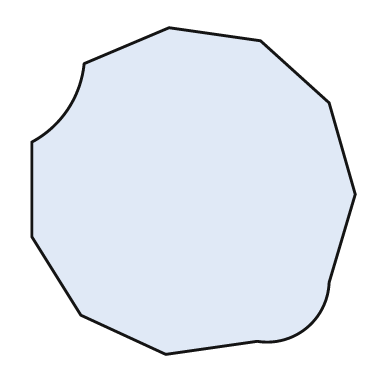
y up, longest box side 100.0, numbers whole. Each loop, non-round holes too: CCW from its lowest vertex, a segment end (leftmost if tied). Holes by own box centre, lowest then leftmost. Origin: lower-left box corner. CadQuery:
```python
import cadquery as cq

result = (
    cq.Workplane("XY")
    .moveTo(41.0, 0.0)
    .lineTo(69.0, 4.0)
    .threePointArc((84.0, 8.0), (91.0, 22.0))
    .lineTo(99.0, 49.0)
    .lineTo(91.0, 77.0)
    .lineTo(70.0, 96.0)
    .lineTo(42.0, 100.0)
    .lineTo(16.0, 89.0)
    .threePointArc((11.0, 75.0), (0.0, 65.0))
    .lineTo(0.0, 36.0)
    .lineTo(15.0, 12.0)
    .close()
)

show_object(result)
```